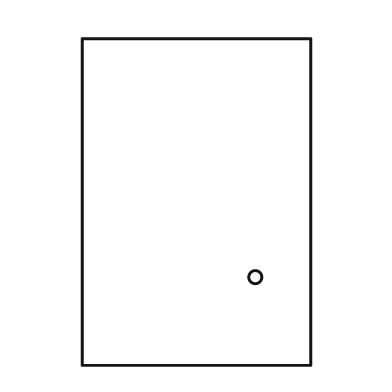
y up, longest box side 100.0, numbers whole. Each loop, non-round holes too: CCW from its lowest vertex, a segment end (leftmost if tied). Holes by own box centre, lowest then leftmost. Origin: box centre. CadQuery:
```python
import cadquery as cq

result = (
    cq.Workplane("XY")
    .moveTo(-35.0, -50.0)
    .lineTo(35.0, -50.0)
    .lineTo(35.0, 50.0)
    .lineTo(-35.0, 50.0)
    .close()
    .moveTo(18.0, -23.0)
    .circle(2.0)
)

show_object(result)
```